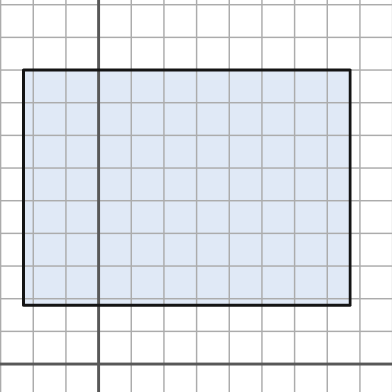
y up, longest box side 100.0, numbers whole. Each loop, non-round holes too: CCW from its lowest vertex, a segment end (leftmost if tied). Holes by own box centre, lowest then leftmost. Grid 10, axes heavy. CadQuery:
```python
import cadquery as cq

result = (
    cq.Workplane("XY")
    .moveTo(-23.0, 18.0)
    .lineTo(77.0, 18.0)
    .lineTo(77.0, 90.0)
    .lineTo(-23.0, 90.0)
    .close()
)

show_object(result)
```